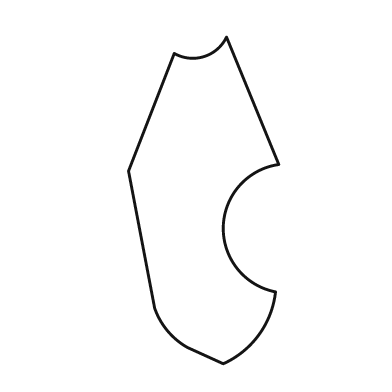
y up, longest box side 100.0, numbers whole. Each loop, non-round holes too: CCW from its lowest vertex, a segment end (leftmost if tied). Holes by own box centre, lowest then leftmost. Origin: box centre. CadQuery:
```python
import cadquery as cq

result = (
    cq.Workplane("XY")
    .moveTo(6.0, -50.0)
    .threePointArc((17.0, -41.0), (22.0, -28.0))
    .threePointArc((6.0, -8.0), (23.0, 11.0))
    .lineTo(7.0, 50.0)
    .threePointArc((0.0, 44.0), (-9.0, 45.0))
    .lineTo(-23.0, 9.0)
    .lineTo(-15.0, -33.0)
    .threePointArc((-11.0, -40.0), (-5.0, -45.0))
    .close()
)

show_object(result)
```